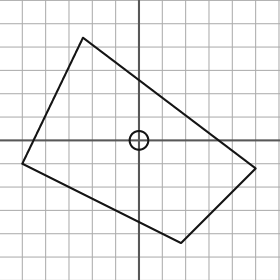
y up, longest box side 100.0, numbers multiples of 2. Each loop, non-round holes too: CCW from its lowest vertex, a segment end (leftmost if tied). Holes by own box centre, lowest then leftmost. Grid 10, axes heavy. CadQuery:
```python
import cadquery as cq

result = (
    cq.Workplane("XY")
    .moveTo(18.0, -44.0)
    .lineTo(50.0, -12.0)
    .lineTo(-24.0, 44.0)
    .lineTo(-50.0, -10.0)
    .close()
    .moveTo(0.0, 0.0)
    .circle(4.0)
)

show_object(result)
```